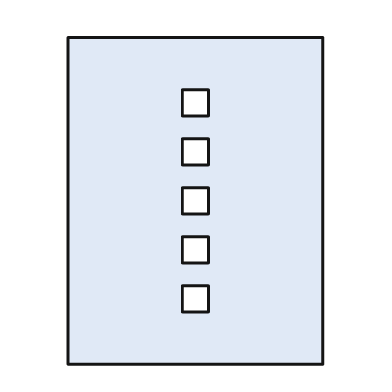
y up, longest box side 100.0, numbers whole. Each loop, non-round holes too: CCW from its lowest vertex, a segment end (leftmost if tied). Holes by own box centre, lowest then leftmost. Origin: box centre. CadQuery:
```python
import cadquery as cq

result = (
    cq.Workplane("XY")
    .moveTo(-39.0, -50.0)
    .lineTo(39.0, -50.0)
    .lineTo(39.0, 50.0)
    .lineTo(-39.0, 50.0)
    .close()
    .moveTo(-4.0, -34.0)
    .lineTo(4.0, -34.0)
    .lineTo(4.0, -26.0)
    .lineTo(-4.0, -26.0)
    .close()
    .moveTo(-4.0, -19.0)
    .lineTo(4.0, -19.0)
    .lineTo(4.0, -11.0)
    .lineTo(-4.0, -11.0)
    .close()
    .moveTo(-4.0, -4.0)
    .lineTo(4.0, -4.0)
    .lineTo(4.0, 4.0)
    .lineTo(-4.0, 4.0)
    .close()
    .moveTo(-4.0, 11.0)
    .lineTo(4.0, 11.0)
    .lineTo(4.0, 19.0)
    .lineTo(-4.0, 19.0)
    .close()
    .moveTo(-4.0, 26.0)
    .lineTo(4.0, 26.0)
    .lineTo(4.0, 34.0)
    .lineTo(-4.0, 34.0)
    .close()
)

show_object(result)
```